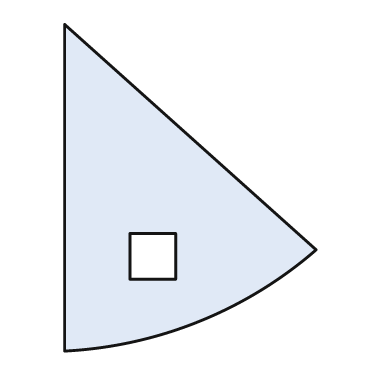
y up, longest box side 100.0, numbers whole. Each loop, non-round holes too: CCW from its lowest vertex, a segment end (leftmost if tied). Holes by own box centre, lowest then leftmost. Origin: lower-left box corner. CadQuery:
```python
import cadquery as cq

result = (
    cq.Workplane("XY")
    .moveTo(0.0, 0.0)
    .threePointArc((41.0, 9.0), (77.0, 31.0))
    .lineTo(0.0, 100.0)
    .close()
    .moveTo(20.0, 22.0)
    .lineTo(34.0, 22.0)
    .lineTo(34.0, 36.0)
    .lineTo(20.0, 36.0)
    .close()
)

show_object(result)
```